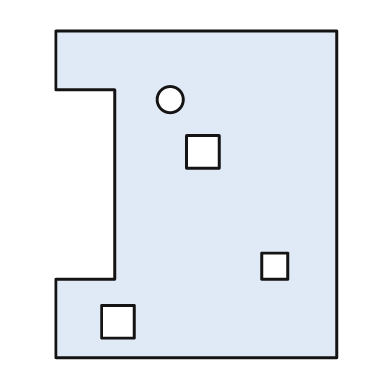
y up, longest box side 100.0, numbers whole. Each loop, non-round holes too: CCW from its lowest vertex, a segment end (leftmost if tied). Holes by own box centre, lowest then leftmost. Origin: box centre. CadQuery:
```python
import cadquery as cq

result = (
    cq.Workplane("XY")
    .moveTo(-43.0, -50.0)
    .lineTo(43.0, -50.0)
    .lineTo(43.0, 50.0)
    .lineTo(-43.0, 50.0)
    .lineTo(-43.0, 32.0)
    .lineTo(-25.0, 32.0)
    .lineTo(-25.0, -26.0)
    .lineTo(-43.0, -26.0)
    .close()
    .moveTo(-29.0, -44.0)
    .lineTo(-19.0, -44.0)
    .lineTo(-19.0, -34.0)
    .lineTo(-29.0, -34.0)
    .close()
    .moveTo(20.0, -26.0)
    .lineTo(28.0, -26.0)
    .lineTo(28.0, -18.0)
    .lineTo(20.0, -18.0)
    .close()
    .moveTo(-3.0, 8.0)
    .lineTo(7.0, 8.0)
    .lineTo(7.0, 18.0)
    .lineTo(-3.0, 18.0)
    .close()
    .moveTo(-8.0, 29.0)
    .circle(4.0)
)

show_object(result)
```